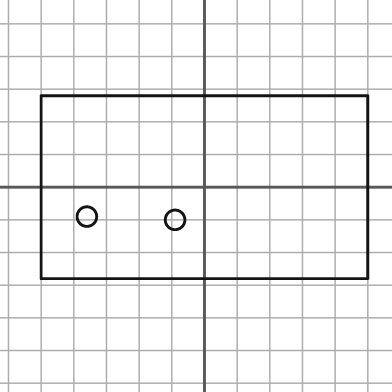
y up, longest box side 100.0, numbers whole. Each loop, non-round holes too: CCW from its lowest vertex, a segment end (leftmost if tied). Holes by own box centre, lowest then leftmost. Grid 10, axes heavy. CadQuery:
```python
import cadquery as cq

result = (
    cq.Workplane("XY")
    .moveTo(-50.0, -28.0)
    .lineTo(50.0, -28.0)
    .lineTo(50.0, 28.0)
    .lineTo(-50.0, 28.0)
    .close()
    .moveTo(-9.0, -10.0)
    .circle(3.0)
    .moveTo(-36.0, -9.0)
    .circle(3.0)
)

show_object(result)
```